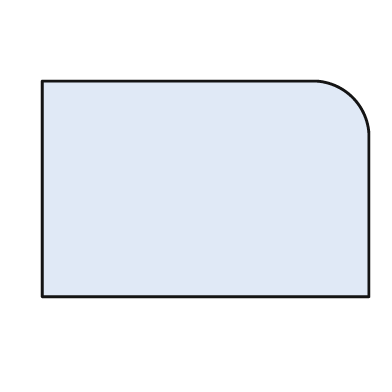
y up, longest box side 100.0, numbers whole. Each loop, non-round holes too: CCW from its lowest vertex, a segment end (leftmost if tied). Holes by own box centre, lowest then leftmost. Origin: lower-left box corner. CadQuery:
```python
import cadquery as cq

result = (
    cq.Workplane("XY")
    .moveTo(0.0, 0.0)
    .lineTo(100.0, 0.0)
    .lineTo(100.0, 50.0)
    .threePointArc((95.0, 61.0), (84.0, 66.0))
    .lineTo(0.0, 66.0)
    .close()
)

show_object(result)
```